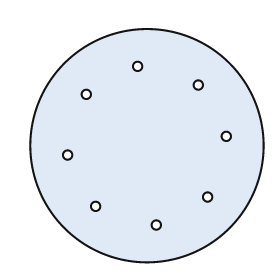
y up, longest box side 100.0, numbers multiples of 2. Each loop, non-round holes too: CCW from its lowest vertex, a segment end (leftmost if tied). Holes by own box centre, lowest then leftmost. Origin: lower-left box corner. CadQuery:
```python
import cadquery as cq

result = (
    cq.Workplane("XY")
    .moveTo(50.0, 50.0)
    .circle(50.0)
    .moveTo(54.0, 16.0)
    .circle(2.0)
    .moveTo(28.0, 24.0)
    .circle(2.0)
    .moveTo(76.0, 28.0)
    .circle(2.0)
    .moveTo(16.0, 46.0)
    .circle(2.0)
    .moveTo(84.0, 54.0)
    .circle(2.0)
    .moveTo(24.0, 72.0)
    .circle(2.0)
    .moveTo(72.0, 76.0)
    .circle(2.0)
    .moveTo(46.0, 84.0)
    .circle(2.0)
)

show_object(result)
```